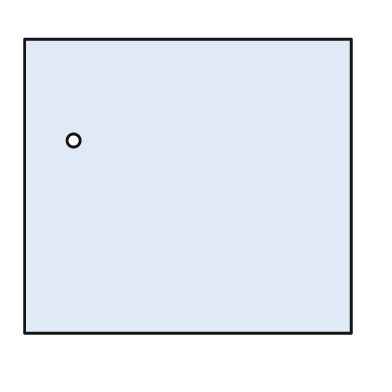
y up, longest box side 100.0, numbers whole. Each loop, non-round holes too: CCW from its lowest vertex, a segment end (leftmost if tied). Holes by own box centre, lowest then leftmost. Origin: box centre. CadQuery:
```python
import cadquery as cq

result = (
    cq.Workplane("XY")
    .moveTo(-50.0, -45.0)
    .lineTo(50.0, -45.0)
    .lineTo(50.0, 45.0)
    .lineTo(-50.0, 45.0)
    .close()
    .moveTo(-35.0, 14.0)
    .circle(2.0)
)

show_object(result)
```